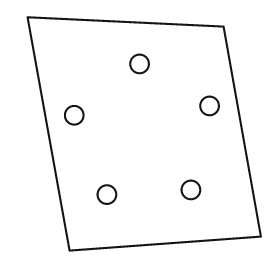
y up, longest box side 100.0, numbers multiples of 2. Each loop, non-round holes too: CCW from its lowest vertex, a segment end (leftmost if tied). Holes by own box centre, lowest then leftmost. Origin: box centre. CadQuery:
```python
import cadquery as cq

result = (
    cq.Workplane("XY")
    .moveTo(-32.0, -50.0)
    .lineTo(50.0, -44.0)
    .lineTo(34.0, 46.0)
    .lineTo(-50.0, 50.0)
    .close()
    .moveTo(-16.0, -26.0)
    .circle(4.0)
    .moveTo(20.0, -24.0)
    .circle(4.0)
    .moveTo(-30.0, 8.0)
    .circle(4.0)
    .moveTo(28.0, 12.0)
    .circle(4.0)
    .moveTo(-2.0, 30.0)
    .circle(4.0)
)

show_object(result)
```